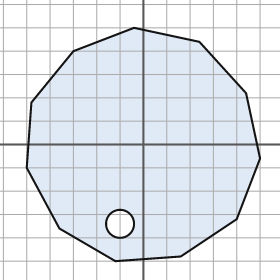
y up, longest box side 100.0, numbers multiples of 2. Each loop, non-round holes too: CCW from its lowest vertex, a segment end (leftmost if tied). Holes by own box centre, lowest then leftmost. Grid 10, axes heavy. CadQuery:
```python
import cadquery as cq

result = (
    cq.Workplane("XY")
    .moveTo(-12.0, -50.0)
    .lineTo(16.0, -48.0)
    .lineTo(40.0, -32.0)
    .lineTo(50.0, -6.0)
    .lineTo(44.0, 22.0)
    .lineTo(24.0, 44.0)
    .lineTo(-4.0, 50.0)
    .lineTo(-30.0, 40.0)
    .lineTo(-48.0, 18.0)
    .lineTo(-50.0, -10.0)
    .lineTo(-36.0, -36.0)
    .close()
    .moveTo(-10.0, -34.0)
    .circle(6.0)
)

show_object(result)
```